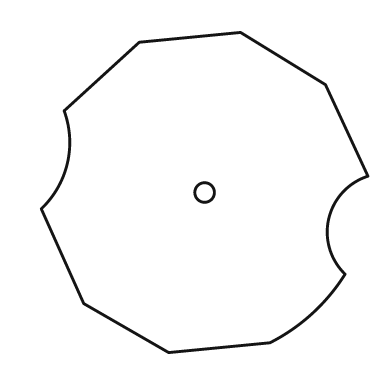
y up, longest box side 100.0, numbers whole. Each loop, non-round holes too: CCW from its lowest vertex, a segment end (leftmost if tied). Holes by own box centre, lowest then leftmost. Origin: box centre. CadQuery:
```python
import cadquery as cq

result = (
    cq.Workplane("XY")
    .moveTo(-11.0, -49.0)
    .lineTo(20.0, -46.0)
    .threePointArc((33.0, -37.0), (43.0, -25.0))
    .threePointArc((38.0, -8.0), (50.0, 5.0))
    .lineTo(37.0, 33.0)
    .lineTo(11.0, 49.0)
    .lineTo(-20.0, 46.0)
    .lineTo(-43.0, 25.0)
    .threePointArc((-42.0, 9.0), (-50.0, -5.0))
    .lineTo(-37.0, -34.0)
    .close()
    .moveTo(0.0, 0.0)
    .circle(3.0)
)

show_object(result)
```